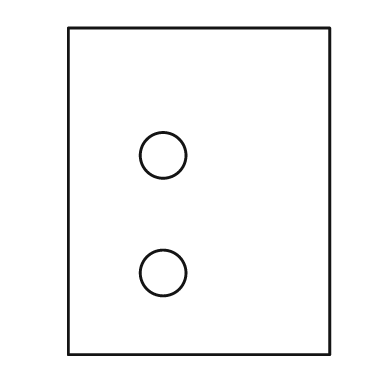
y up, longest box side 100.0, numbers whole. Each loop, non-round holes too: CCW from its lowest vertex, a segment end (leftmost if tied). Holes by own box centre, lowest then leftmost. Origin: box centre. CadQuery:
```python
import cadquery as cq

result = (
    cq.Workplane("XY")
    .moveTo(-40.0, -50.0)
    .lineTo(40.0, -50.0)
    .lineTo(40.0, 50.0)
    .lineTo(-40.0, 50.0)
    .close()
    .moveTo(-11.0, -25.0)
    .circle(7.0)
    .moveTo(-11.0, 11.0)
    .circle(7.0)
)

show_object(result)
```